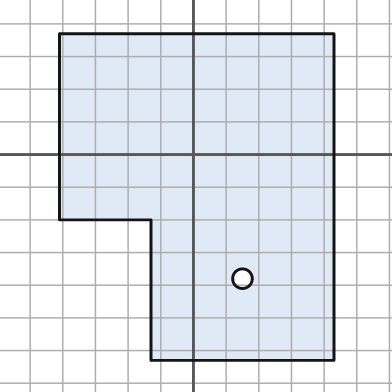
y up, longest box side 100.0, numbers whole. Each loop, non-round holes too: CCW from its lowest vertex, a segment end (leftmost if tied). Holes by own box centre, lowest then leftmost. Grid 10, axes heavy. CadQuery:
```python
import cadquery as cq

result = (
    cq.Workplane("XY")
    .moveTo(-13.0, -63.0)
    .lineTo(43.0, -63.0)
    .lineTo(43.0, 37.0)
    .lineTo(-41.0, 37.0)
    .lineTo(-41.0, -20.0)
    .lineTo(-13.0, -20.0)
    .close()
    .moveTo(15.0, -38.0)
    .circle(3.0)
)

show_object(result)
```